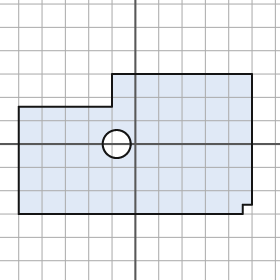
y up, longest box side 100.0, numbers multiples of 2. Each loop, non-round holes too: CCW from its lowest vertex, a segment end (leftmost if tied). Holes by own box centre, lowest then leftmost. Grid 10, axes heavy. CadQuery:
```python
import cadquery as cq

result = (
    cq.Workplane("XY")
    .moveTo(-50.0, -30.0)
    .lineTo(46.0, -30.0)
    .lineTo(46.0, -26.0)
    .lineTo(50.0, -26.0)
    .lineTo(50.0, 30.0)
    .lineTo(-10.0, 30.0)
    .lineTo(-10.0, 16.0)
    .lineTo(-50.0, 16.0)
    .close()
    .moveTo(-8.0, 0.0)
    .circle(6.0)
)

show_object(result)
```